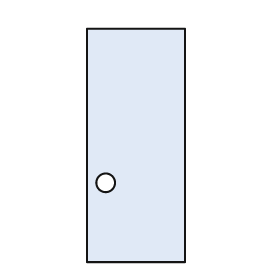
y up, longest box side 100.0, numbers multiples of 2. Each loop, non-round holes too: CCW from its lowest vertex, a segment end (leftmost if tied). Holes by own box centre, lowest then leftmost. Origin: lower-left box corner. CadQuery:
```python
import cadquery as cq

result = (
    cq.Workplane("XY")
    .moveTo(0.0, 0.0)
    .lineTo(42.0, 0.0)
    .lineTo(42.0, 100.0)
    .lineTo(0.0, 100.0)
    .close()
    .moveTo(8.0, 34.0)
    .circle(4.0)
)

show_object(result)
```